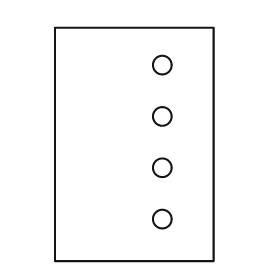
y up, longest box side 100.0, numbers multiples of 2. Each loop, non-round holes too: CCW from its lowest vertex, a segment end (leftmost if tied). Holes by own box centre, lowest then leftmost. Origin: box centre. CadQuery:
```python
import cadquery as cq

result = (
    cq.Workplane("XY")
    .moveTo(-34.0, -50.0)
    .lineTo(34.0, -50.0)
    .lineTo(34.0, 50.0)
    .lineTo(-34.0, 50.0)
    .close()
    .moveTo(12.0, -32.0)
    .circle(4.0)
    .moveTo(12.0, -10.0)
    .circle(4.0)
    .moveTo(12.0, 12.0)
    .circle(4.0)
    .moveTo(12.0, 34.0)
    .circle(4.0)
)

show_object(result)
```